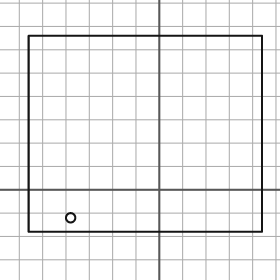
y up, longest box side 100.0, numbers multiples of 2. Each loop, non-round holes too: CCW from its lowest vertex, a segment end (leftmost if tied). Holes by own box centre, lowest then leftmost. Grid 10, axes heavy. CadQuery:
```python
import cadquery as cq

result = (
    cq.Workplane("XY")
    .moveTo(-56.0, -18.0)
    .lineTo(44.0, -18.0)
    .lineTo(44.0, 66.0)
    .lineTo(-56.0, 66.0)
    .close()
    .moveTo(-38.0, -12.0)
    .circle(2.0)
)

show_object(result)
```